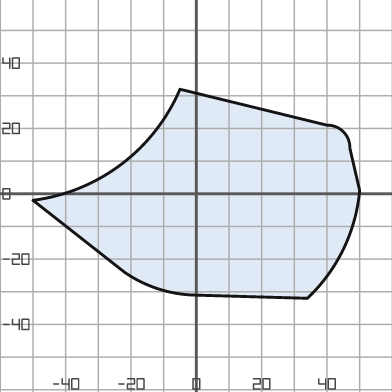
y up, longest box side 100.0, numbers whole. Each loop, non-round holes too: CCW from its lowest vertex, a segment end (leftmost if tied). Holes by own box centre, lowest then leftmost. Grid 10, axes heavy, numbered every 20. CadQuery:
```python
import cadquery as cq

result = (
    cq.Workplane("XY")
    .moveTo(34.0, -32.0)
    .threePointArc((45.0, -17.0), (50.0, 1.0))
    .lineTo(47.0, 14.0)
    .threePointArc((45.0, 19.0), (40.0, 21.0))
    .lineTo(-5.0, 32.0)
    .threePointArc((-23.0, 9.0), (-50.0, -2.0))
    .lineTo(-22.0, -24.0)
    .threePointArc((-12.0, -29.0), (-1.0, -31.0))
    .close()
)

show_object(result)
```